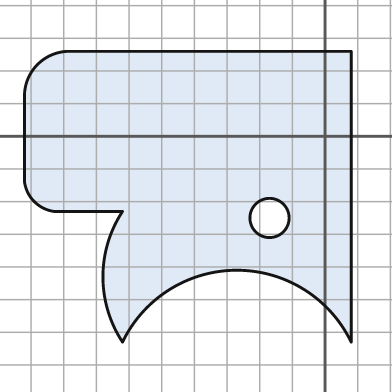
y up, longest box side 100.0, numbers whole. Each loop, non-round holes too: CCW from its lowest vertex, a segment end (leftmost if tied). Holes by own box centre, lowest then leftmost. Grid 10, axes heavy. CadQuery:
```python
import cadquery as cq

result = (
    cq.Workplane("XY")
    .moveTo(-62.0, -63.0)
    .threePointArc((-27.0, -41.0), (8.0, -63.0))
    .lineTo(8.0, 26.0)
    .lineTo(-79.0, 26.0)
    .threePointArc((-88.0, 22.0), (-92.0, 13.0))
    .lineTo(-92.0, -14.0)
    .threePointArc((-89.0, -20.0), (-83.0, -23.0))
    .lineTo(-62.0, -23.0)
    .threePointArc((-68.0, -43.0), (-62.0, -63.0))
    .close()
    .moveTo(-17.0, -25.0)
    .circle(6.0)
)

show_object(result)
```